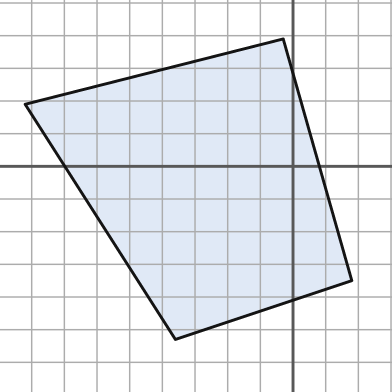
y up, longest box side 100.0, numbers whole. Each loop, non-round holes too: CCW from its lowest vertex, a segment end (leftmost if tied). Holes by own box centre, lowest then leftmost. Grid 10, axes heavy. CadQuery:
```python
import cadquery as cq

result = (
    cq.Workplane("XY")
    .moveTo(-36.0, -53.0)
    .lineTo(18.0, -35.0)
    .lineTo(-3.0, 39.0)
    .lineTo(-82.0, 19.0)
    .close()
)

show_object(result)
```